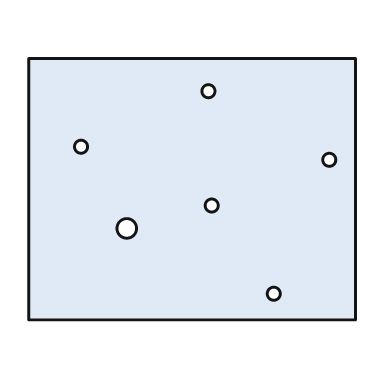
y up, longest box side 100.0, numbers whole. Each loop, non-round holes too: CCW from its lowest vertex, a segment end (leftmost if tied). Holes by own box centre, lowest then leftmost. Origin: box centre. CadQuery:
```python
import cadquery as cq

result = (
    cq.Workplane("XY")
    .moveTo(-50.0, -40.0)
    .lineTo(50.0, -40.0)
    .lineTo(50.0, 40.0)
    .lineTo(-50.0, 40.0)
    .close()
    .moveTo(25.0, -32.0)
    .circle(2.0)
    .moveTo(-20.0, -12.0)
    .circle(3.0)
    .moveTo(6.0, -5.0)
    .circle(2.0)
    .moveTo(42.0, 9.0)
    .circle(2.0)
    .moveTo(-34.0, 13.0)
    .circle(2.0)
    .moveTo(5.0, 30.0)
    .circle(2.0)
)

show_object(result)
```